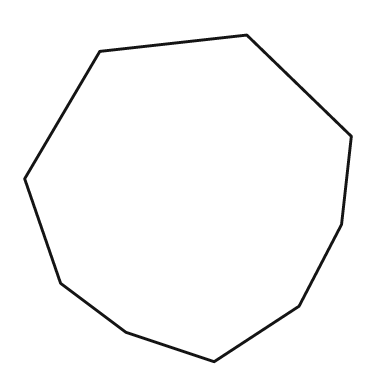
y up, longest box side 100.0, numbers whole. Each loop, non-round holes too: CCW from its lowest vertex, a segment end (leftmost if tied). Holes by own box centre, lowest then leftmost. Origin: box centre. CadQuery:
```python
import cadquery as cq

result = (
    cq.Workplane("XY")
    .moveTo(8.0, -50.0)
    .lineTo(34.0, -33.0)
    .lineTo(47.0, -8.0)
    .lineTo(50.0, 19.0)
    .lineTo(18.0, 50.0)
    .lineTo(-27.0, 45.0)
    .lineTo(-50.0, 6.0)
    .lineTo(-39.0, -26.0)
    .lineTo(-19.0, -41.0)
    .close()
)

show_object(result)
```